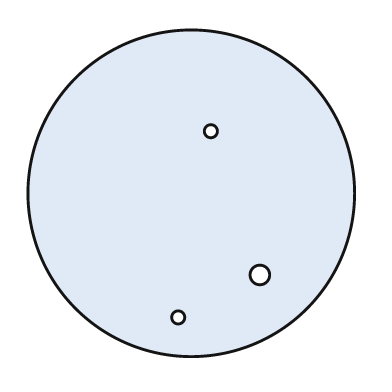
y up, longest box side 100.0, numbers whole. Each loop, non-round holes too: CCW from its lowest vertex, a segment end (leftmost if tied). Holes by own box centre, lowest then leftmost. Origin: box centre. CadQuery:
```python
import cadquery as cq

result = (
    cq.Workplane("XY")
    .moveTo(0.0, 0.0)
    .circle(50.0)
    .moveTo(-4.0, -38.0)
    .circle(2.0)
    .moveTo(21.0, -25.0)
    .circle(3.0)
    .moveTo(6.0, 19.0)
    .circle(2.0)
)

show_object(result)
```